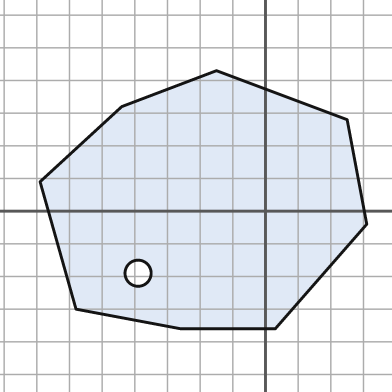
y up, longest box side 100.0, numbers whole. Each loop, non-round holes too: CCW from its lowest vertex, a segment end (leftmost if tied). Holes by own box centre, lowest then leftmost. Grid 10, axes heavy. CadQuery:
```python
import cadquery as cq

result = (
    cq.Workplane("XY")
    .moveTo(-26.0, -36.0)
    .lineTo(3.0, -36.0)
    .lineTo(31.0, -4.0)
    .lineTo(25.0, 28.0)
    .lineTo(-15.0, 43.0)
    .lineTo(-44.0, 32.0)
    .lineTo(-69.0, 9.0)
    .lineTo(-58.0, -30.0)
    .close()
    .moveTo(-39.0, -19.0)
    .circle(4.0)
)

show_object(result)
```